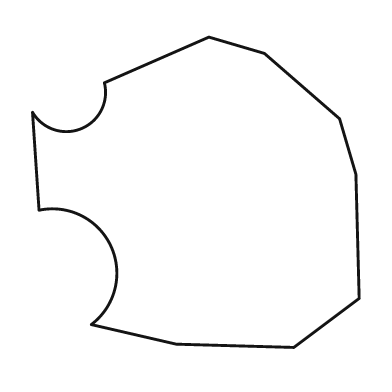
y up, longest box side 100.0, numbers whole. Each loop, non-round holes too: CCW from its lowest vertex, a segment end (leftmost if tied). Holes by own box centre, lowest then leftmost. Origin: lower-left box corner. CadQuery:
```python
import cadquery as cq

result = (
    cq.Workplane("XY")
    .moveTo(80.0, 0.0)
    .lineTo(100.0, 15.0)
    .lineTo(99.0, 53.0)
    .lineTo(94.0, 70.0)
    .lineTo(71.0, 90.0)
    .lineTo(54.0, 95.0)
    .lineTo(22.0, 81.0)
    .threePointArc((15.0, 67.0), (0.0, 72.0))
    .lineTo(2.0, 42.0)
    .threePointArc((24.0, 31.0), (18.0, 7.0))
    .lineTo(44.0, 1.0)
    .close()
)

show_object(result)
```